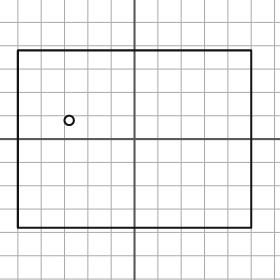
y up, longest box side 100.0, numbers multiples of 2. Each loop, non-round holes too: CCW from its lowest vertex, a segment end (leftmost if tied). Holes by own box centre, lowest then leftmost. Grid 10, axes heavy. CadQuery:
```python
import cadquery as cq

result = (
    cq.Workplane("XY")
    .moveTo(-50.0, -38.0)
    .lineTo(50.0, -38.0)
    .lineTo(50.0, 38.0)
    .lineTo(-50.0, 38.0)
    .close()
    .moveTo(-28.0, 8.0)
    .circle(2.0)
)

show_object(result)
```